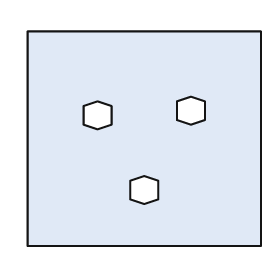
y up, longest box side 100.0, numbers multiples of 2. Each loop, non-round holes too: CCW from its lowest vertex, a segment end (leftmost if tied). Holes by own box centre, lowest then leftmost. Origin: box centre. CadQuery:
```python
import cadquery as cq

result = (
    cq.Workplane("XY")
    .moveTo(-50.0, -46.0)
    .lineTo(50.0, -46.0)
    .lineTo(50.0, 46.0)
    .lineTo(-50.0, 46.0)
    .close()
    .moveTo(0.0, -28.0)
    .lineTo(6.0, -26.0)
    .lineTo(6.0, -18.0)
    .lineTo(0.0, -16.0)
    .lineTo(-6.0, -18.0)
    .lineTo(-6.0, -26.0)
    .close()
    .moveTo(-20.0, 4.0)
    .lineTo(-14.0, 6.0)
    .lineTo(-14.0, 14.0)
    .lineTo(-20.0, 16.0)
    .lineTo(-26.0, 14.0)
    .lineTo(-26.0, 6.0)
    .close()
    .moveTo(20.0, 6.0)
    .lineTo(26.0, 8.0)
    .lineTo(26.0, 16.0)
    .lineTo(20.0, 18.0)
    .lineTo(14.0, 16.0)
    .lineTo(14.0, 8.0)
    .close()
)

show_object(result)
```